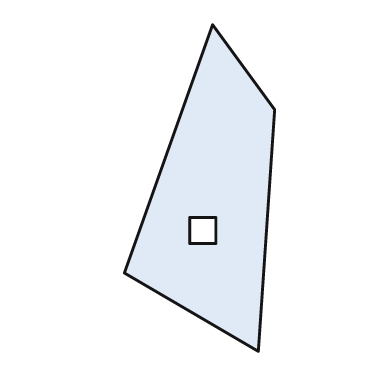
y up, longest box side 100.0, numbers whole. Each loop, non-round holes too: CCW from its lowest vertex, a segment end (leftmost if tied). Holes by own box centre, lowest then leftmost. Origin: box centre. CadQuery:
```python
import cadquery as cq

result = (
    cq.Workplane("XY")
    .moveTo(18.0, -50.0)
    .lineTo(23.0, 24.0)
    .lineTo(4.0, 50.0)
    .lineTo(-23.0, -26.0)
    .close()
    .moveTo(-3.0, -17.0)
    .lineTo(5.0, -17.0)
    .lineTo(5.0, -9.0)
    .lineTo(-3.0, -9.0)
    .close()
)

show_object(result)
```